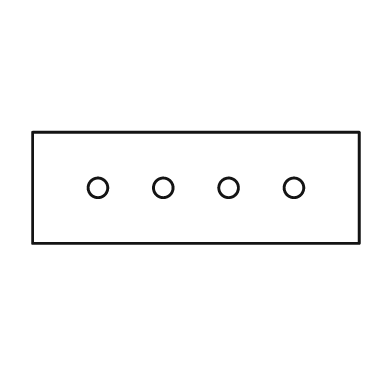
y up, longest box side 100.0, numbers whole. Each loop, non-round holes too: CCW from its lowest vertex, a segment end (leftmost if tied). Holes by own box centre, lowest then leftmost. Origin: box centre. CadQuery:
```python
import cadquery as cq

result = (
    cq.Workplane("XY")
    .moveTo(-50.0, -17.0)
    .lineTo(50.0, -17.0)
    .lineTo(50.0, 17.0)
    .lineTo(-50.0, 17.0)
    .close()
    .moveTo(-30.0, 0.0)
    .circle(3.0)
    .moveTo(-10.0, 0.0)
    .circle(3.0)
    .moveTo(10.0, 0.0)
    .circle(3.0)
    .moveTo(30.0, 0.0)
    .circle(3.0)
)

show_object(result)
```